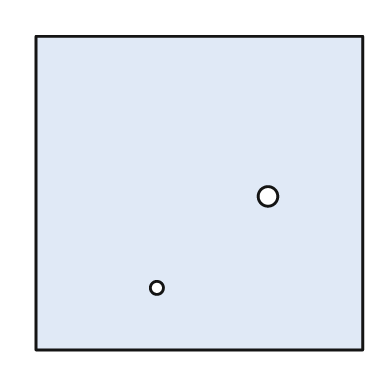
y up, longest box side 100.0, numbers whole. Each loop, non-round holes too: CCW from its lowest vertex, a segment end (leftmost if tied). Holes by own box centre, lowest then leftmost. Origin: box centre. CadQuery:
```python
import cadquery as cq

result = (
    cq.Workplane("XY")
    .moveTo(-50.0, -48.0)
    .lineTo(50.0, -48.0)
    .lineTo(50.0, 48.0)
    .lineTo(-50.0, 48.0)
    .close()
    .moveTo(-13.0, -29.0)
    .circle(2.0)
    .moveTo(21.0, -1.0)
    .circle(3.0)
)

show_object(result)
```